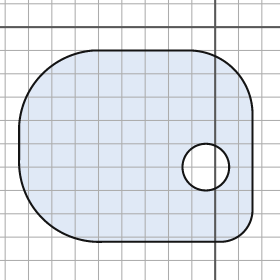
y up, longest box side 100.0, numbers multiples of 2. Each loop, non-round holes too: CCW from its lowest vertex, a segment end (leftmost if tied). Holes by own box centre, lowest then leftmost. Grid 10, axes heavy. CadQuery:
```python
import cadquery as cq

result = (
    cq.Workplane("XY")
    .moveTo(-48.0, -92.0)
    .lineTo(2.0, -92.0)
    .threePointArc((12.0, -88.0), (16.0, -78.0))
    .lineTo(16.0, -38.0)
    .threePointArc((8.0, -18.0), (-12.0, -10.0))
    .lineTo(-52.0, -10.0)
    .threePointArc((-74.0, -20.0), (-84.0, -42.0))
    .lineTo(-84.0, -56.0)
    .threePointArc((-74.0, -82.0), (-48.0, -92.0))
    .close()
    .moveTo(-4.0, -60.0)
    .circle(10.0)
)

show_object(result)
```